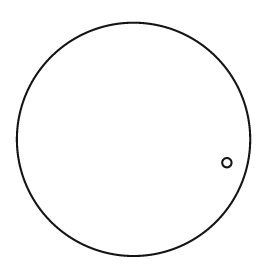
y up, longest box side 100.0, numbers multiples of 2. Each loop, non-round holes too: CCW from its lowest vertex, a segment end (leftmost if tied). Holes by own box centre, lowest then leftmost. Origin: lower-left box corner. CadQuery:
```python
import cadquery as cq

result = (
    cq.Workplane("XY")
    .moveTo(50.0, 50.0)
    .circle(50.0)
    .moveTo(90.0, 40.0)
    .circle(2.0)
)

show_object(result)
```